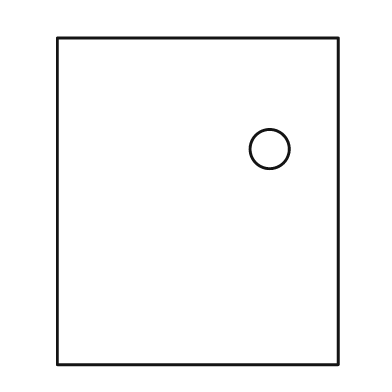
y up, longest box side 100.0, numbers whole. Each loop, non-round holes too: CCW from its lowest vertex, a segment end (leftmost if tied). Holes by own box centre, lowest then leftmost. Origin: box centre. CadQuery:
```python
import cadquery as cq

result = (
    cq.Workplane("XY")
    .moveTo(-43.0, -50.0)
    .lineTo(43.0, -50.0)
    .lineTo(43.0, 50.0)
    .lineTo(-43.0, 50.0)
    .close()
    .moveTo(22.0, 16.0)
    .circle(6.0)
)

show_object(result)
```